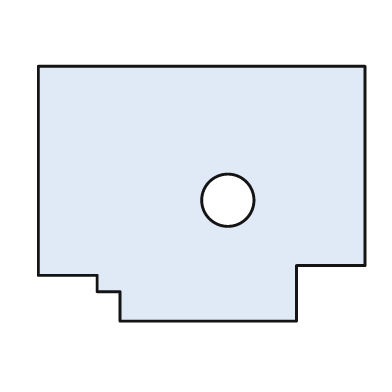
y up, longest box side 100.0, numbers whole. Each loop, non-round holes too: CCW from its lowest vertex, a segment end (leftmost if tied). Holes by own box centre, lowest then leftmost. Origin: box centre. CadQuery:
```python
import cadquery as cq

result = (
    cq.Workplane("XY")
    .moveTo(-25.0, -39.0)
    .lineTo(29.0, -39.0)
    .lineTo(29.0, -22.0)
    .lineTo(50.0, -22.0)
    .lineTo(50.0, 39.0)
    .lineTo(-50.0, 39.0)
    .lineTo(-50.0, -25.0)
    .lineTo(-32.0, -25.0)
    .lineTo(-32.0, -30.0)
    .lineTo(-25.0, -30.0)
    .close()
    .moveTo(8.0, -2.0)
    .circle(8.0)
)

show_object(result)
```